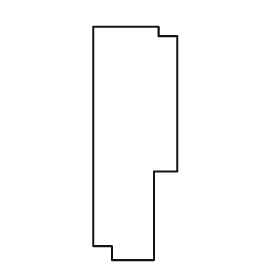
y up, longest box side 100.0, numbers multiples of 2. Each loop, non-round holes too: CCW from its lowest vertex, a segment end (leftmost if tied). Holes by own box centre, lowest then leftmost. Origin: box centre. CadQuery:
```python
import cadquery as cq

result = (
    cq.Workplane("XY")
    .moveTo(-10.0, -50.0)
    .lineTo(8.0, -50.0)
    .lineTo(8.0, -12.0)
    .lineTo(18.0, -12.0)
    .lineTo(18.0, 46.0)
    .lineTo(10.0, 46.0)
    .lineTo(10.0, 50.0)
    .lineTo(-18.0, 50.0)
    .lineTo(-18.0, -44.0)
    .lineTo(-10.0, -44.0)
    .close()
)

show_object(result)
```